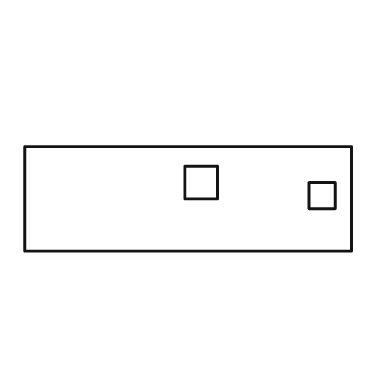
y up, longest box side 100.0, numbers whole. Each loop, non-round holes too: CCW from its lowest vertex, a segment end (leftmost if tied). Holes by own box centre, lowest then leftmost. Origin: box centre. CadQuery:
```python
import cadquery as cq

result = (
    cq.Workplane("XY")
    .moveTo(-50.0, -16.0)
    .lineTo(50.0, -16.0)
    .lineTo(50.0, 16.0)
    .lineTo(-50.0, 16.0)
    .close()
    .moveTo(37.0, -3.0)
    .lineTo(45.0, -3.0)
    .lineTo(45.0, 5.0)
    .lineTo(37.0, 5.0)
    .close()
    .moveTo(-1.0, 0.0)
    .lineTo(9.0, 0.0)
    .lineTo(9.0, 10.0)
    .lineTo(-1.0, 10.0)
    .close()
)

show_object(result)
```